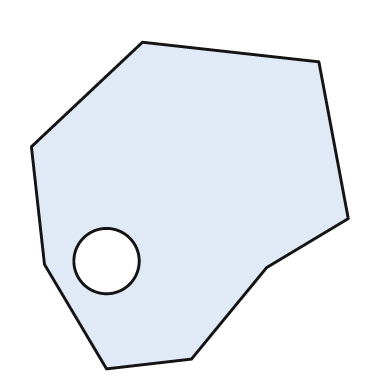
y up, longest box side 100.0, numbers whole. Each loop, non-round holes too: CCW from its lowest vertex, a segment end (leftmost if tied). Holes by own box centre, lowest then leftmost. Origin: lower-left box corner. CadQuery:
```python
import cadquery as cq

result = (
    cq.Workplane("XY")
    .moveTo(23.0, 0.0)
    .lineTo(49.0, 3.0)
    .lineTo(72.0, 31.0)
    .lineTo(97.0, 46.0)
    .lineTo(88.0, 94.0)
    .lineTo(34.0, 100.0)
    .lineTo(0.0, 68.0)
    .lineTo(4.0, 32.0)
    .close()
    .moveTo(23.0, 33.0)
    .circle(10.0)
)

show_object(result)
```